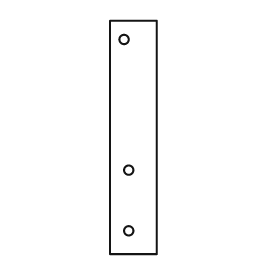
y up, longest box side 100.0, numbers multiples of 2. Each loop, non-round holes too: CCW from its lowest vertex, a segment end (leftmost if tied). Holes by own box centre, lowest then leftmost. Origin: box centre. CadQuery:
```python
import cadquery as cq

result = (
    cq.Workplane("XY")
    .moveTo(-10.0, -50.0)
    .lineTo(10.0, -50.0)
    .lineTo(10.0, 50.0)
    .lineTo(-10.0, 50.0)
    .close()
    .moveTo(-2.0, -40.0)
    .circle(2.0)
    .moveTo(-2.0, -14.0)
    .circle(2.0)
    .moveTo(-4.0, 42.0)
    .circle(2.0)
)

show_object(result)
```